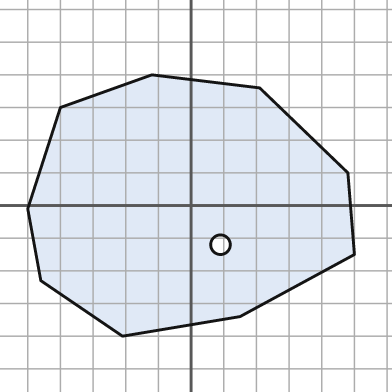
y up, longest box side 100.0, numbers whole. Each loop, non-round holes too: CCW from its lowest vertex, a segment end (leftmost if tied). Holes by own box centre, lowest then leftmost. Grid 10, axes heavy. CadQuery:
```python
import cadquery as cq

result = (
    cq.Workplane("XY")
    .moveTo(-21.0, -40.0)
    .lineTo(15.0, -34.0)
    .lineTo(50.0, -15.0)
    .lineTo(48.0, 10.0)
    .lineTo(21.0, 36.0)
    .lineTo(-12.0, 40.0)
    .lineTo(-40.0, 30.0)
    .lineTo(-50.0, -1.0)
    .lineTo(-46.0, -23.0)
    .close()
    .moveTo(9.0, -12.0)
    .circle(3.0)
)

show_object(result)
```